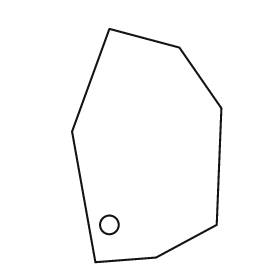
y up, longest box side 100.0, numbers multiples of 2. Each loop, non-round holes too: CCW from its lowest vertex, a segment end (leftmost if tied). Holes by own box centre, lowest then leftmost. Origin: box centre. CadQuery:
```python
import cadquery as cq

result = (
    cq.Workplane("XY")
    .moveTo(-22.0, -50.0)
    .lineTo(4.0, -48.0)
    .lineTo(30.0, -34.0)
    .lineTo(32.0, 16.0)
    .lineTo(14.0, 42.0)
    .lineTo(-16.0, 50.0)
    .lineTo(-32.0, 6.0)
    .close()
    .moveTo(-16.0, -34.0)
    .circle(4.0)
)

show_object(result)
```